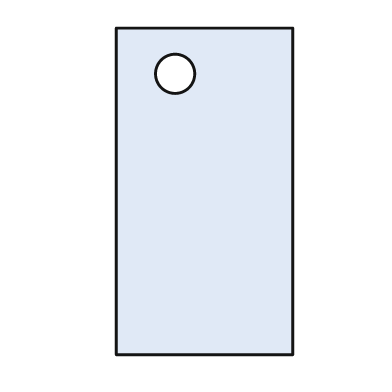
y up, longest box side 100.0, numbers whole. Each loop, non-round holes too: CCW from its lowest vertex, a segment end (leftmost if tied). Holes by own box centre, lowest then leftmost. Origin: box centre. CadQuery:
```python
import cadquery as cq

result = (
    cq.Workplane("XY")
    .moveTo(-27.0, -50.0)
    .lineTo(27.0, -50.0)
    .lineTo(27.0, 50.0)
    .lineTo(-27.0, 50.0)
    .close()
    .moveTo(-9.0, 36.0)
    .circle(6.0)
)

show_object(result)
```